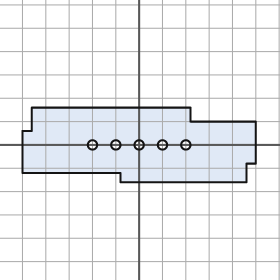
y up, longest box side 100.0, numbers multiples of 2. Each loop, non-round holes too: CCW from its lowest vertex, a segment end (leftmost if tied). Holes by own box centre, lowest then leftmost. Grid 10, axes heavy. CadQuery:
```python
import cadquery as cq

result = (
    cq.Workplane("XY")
    .moveTo(-8.0, -16.0)
    .lineTo(46.0, -16.0)
    .lineTo(46.0, -8.0)
    .lineTo(50.0, -8.0)
    .lineTo(50.0, 10.0)
    .lineTo(22.0, 10.0)
    .lineTo(22.0, 16.0)
    .lineTo(-46.0, 16.0)
    .lineTo(-46.0, 6.0)
    .lineTo(-50.0, 6.0)
    .lineTo(-50.0, -12.0)
    .lineTo(-8.0, -12.0)
    .close()
    .moveTo(-20.0, 0.0)
    .circle(2.0)
    .moveTo(-10.0, 0.0)
    .circle(2.0)
    .moveTo(0.0, 0.0)
    .circle(2.0)
    .moveTo(10.0, 0.0)
    .circle(2.0)
    .moveTo(20.0, 0.0)
    .circle(2.0)
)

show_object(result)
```